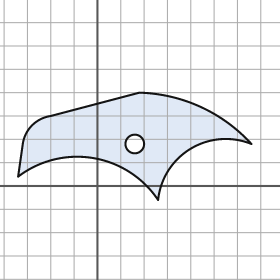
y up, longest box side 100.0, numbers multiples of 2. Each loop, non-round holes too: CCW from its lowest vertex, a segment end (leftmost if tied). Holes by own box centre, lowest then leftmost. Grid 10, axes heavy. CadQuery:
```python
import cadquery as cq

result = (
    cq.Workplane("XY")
    .moveTo(26.0, -6.0)
    .threePointArc((40.0, 16.0), (66.0, 18.0))
    .threePointArc((44.0, 34.0), (18.0, 40.0))
    .lineTo(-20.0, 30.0)
    .threePointArc((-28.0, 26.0), (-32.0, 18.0))
    .lineTo(-34.0, 4.0)
    .threePointArc((-2.0, 12.0), (26.0, -6.0))
    .close()
    .moveTo(16.0, 18.0)
    .circle(4.0)
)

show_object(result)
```